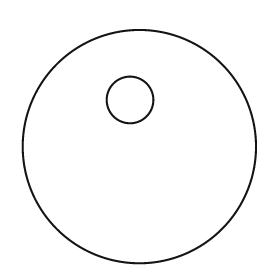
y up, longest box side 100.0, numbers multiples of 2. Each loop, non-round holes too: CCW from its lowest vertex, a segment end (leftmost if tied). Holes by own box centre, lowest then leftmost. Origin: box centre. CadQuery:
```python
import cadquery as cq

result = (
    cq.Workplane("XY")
    .moveTo(0.0, 0.0)
    .circle(50.0)
    .moveTo(-4.0, 20.0)
    .circle(10.0)
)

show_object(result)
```